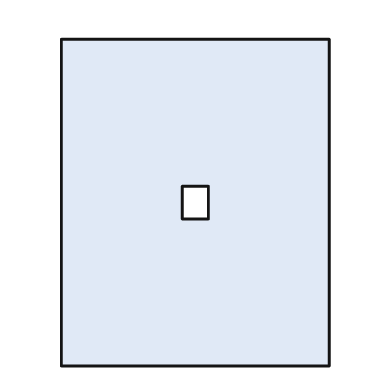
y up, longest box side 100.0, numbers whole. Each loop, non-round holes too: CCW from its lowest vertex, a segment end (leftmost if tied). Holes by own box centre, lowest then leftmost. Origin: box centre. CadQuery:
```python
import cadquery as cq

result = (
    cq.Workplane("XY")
    .moveTo(-41.0, -50.0)
    .lineTo(41.0, -50.0)
    .lineTo(41.0, 50.0)
    .lineTo(-41.0, 50.0)
    .close()
    .moveTo(-4.0, -5.0)
    .lineTo(4.0, -5.0)
    .lineTo(4.0, 5.0)
    .lineTo(-4.0, 5.0)
    .close()
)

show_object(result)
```